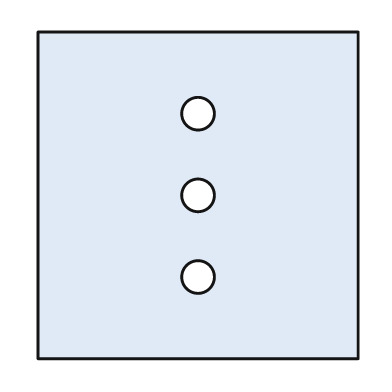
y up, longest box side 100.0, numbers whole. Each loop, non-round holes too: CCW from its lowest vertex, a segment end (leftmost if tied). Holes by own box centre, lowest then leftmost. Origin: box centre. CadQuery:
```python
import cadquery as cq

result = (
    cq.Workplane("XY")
    .moveTo(-49.0, -50.0)
    .lineTo(49.0, -50.0)
    .lineTo(49.0, 50.0)
    .lineTo(-49.0, 50.0)
    .close()
    .moveTo(0.0, -25.0)
    .circle(5.0)
    .moveTo(0.0, 0.0)
    .circle(5.0)
    .moveTo(0.0, 25.0)
    .circle(5.0)
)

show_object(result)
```